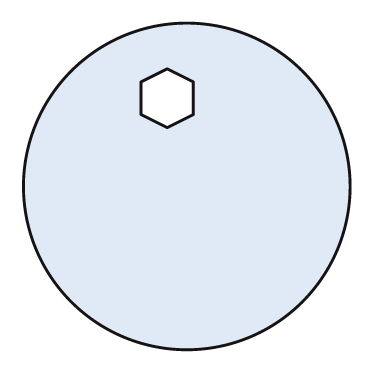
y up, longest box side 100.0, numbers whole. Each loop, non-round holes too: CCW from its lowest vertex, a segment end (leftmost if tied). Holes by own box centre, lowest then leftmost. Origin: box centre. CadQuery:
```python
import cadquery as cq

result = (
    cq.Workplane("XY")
    .moveTo(0.0, 0.0)
    .circle(50.0)
    .moveTo(-6.0, 18.0)
    .lineTo(2.0, 22.0)
    .lineTo(2.0, 32.0)
    .lineTo(-6.0, 36.0)
    .lineTo(-14.0, 32.0)
    .lineTo(-14.0, 22.0)
    .close()
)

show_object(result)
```